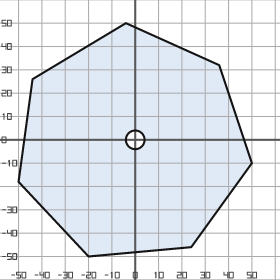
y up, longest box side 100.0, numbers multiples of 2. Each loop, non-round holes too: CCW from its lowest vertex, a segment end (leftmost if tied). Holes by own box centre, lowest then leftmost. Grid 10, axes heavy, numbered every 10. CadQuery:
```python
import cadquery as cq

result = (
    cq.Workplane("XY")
    .moveTo(-20.0, -50.0)
    .lineTo(24.0, -46.0)
    .lineTo(50.0, -10.0)
    .lineTo(36.0, 32.0)
    .lineTo(-4.0, 50.0)
    .lineTo(-44.0, 26.0)
    .lineTo(-50.0, -18.0)
    .close()
    .moveTo(0.0, 0.0)
    .circle(4.0)
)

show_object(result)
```